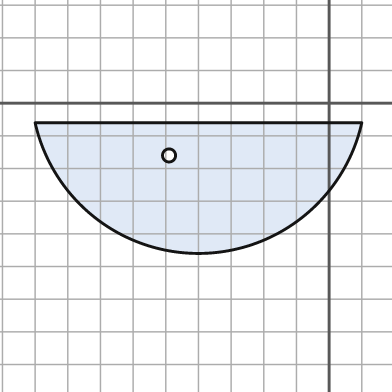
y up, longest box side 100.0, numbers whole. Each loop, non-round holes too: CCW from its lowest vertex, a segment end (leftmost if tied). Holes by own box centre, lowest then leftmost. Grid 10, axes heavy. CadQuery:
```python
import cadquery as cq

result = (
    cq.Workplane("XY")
    .moveTo(-90.0, -6.0)
    .threePointArc((-40.0, -46.0), (10.0, -6.0))
    .close()
    .moveTo(-49.0, -16.0)
    .circle(2.0)
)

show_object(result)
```